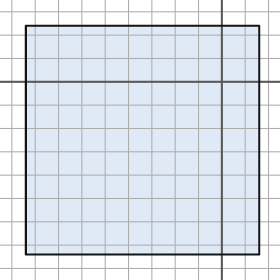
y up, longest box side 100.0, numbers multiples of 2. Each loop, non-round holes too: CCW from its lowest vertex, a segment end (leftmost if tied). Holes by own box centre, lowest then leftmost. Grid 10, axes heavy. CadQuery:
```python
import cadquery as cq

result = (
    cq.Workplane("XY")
    .moveTo(-84.0, -74.0)
    .lineTo(16.0, -74.0)
    .lineTo(16.0, 24.0)
    .lineTo(-84.0, 24.0)
    .close()
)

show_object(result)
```